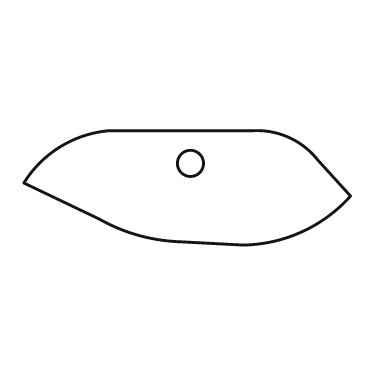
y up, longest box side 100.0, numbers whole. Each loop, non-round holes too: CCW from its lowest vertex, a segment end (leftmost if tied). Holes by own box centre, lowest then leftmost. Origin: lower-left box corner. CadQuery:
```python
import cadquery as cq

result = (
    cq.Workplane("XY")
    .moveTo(67.0, 0.0)
    .threePointArc((85.0, 4.0), (100.0, 15.0))
    .lineTo(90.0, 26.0)
    .threePointArc((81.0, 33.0), (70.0, 35.0))
    .lineTo(26.0, 35.0)
    .threePointArc((11.0, 30.0), (0.0, 19.0))
    .lineTo(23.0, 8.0)
    .threePointArc((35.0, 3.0), (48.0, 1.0))
    .close()
    .moveTo(51.0, 25.0)
    .circle(4.0)
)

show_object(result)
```